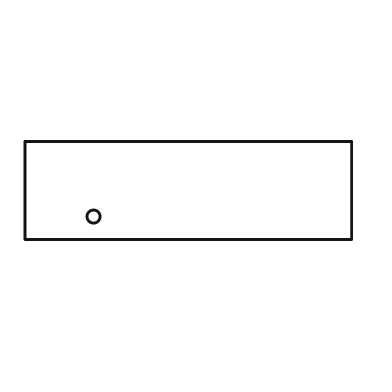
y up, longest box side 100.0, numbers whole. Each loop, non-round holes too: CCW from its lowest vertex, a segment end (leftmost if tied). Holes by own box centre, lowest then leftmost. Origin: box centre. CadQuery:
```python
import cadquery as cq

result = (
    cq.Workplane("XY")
    .moveTo(-50.0, -15.0)
    .lineTo(50.0, -15.0)
    .lineTo(50.0, 15.0)
    .lineTo(-50.0, 15.0)
    .close()
    .moveTo(-29.0, -8.0)
    .circle(2.0)
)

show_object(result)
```